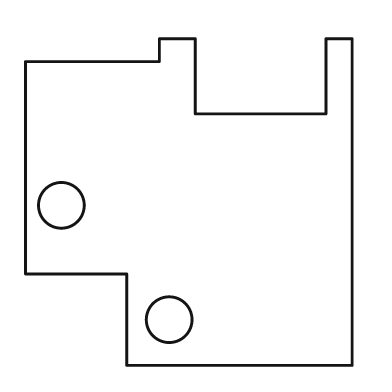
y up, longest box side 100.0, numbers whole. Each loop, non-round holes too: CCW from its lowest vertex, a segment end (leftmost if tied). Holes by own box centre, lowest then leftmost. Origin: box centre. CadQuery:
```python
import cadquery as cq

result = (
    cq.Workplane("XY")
    .moveTo(-19.0, -50.0)
    .lineTo(50.0, -50.0)
    .lineTo(50.0, 50.0)
    .lineTo(42.0, 50.0)
    .lineTo(42.0, 27.0)
    .lineTo(2.0, 27.0)
    .lineTo(2.0, 50.0)
    .lineTo(-9.0, 50.0)
    .lineTo(-9.0, 43.0)
    .lineTo(-50.0, 43.0)
    .lineTo(-50.0, -22.0)
    .lineTo(-19.0, -22.0)
    .close()
    .moveTo(-6.0, -36.0)
    .circle(7.0)
    .moveTo(-39.0, -1.0)
    .circle(7.0)
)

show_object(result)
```